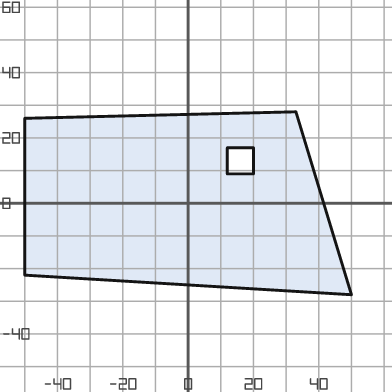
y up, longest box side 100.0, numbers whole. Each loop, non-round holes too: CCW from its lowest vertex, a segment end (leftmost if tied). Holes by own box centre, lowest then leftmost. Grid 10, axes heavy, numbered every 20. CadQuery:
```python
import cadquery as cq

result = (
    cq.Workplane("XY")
    .moveTo(50.0, -28.0)
    .lineTo(33.0, 28.0)
    .lineTo(-50.0, 26.0)
    .lineTo(-50.0, -22.0)
    .close()
    .moveTo(12.0, 9.0)
    .lineTo(20.0, 9.0)
    .lineTo(20.0, 17.0)
    .lineTo(12.0, 17.0)
    .close()
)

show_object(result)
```